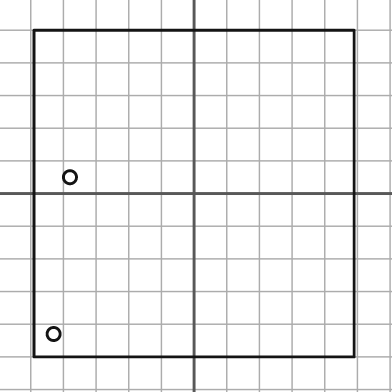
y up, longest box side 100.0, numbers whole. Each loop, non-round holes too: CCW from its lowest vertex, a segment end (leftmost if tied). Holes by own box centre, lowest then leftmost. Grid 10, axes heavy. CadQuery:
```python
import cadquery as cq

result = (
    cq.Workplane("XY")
    .moveTo(-49.0, -50.0)
    .lineTo(49.0, -50.0)
    .lineTo(49.0, 50.0)
    .lineTo(-49.0, 50.0)
    .close()
    .moveTo(-43.0, -43.0)
    .circle(2.0)
    .moveTo(-38.0, 5.0)
    .circle(2.0)
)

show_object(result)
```